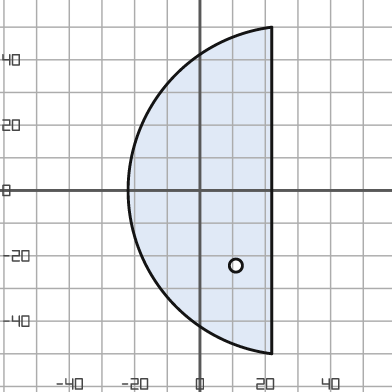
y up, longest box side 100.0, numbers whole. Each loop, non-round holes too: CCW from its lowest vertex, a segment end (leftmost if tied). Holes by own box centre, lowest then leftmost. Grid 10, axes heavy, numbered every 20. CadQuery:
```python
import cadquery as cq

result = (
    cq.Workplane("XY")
    .moveTo(22.0, -50.0)
    .lineTo(22.0, 50.0)
    .threePointArc((-22.0, 0.0), (22.0, -50.0))
    .close()
    .moveTo(11.0, -23.0)
    .circle(2.0)
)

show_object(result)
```